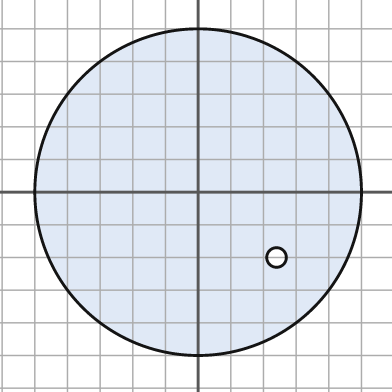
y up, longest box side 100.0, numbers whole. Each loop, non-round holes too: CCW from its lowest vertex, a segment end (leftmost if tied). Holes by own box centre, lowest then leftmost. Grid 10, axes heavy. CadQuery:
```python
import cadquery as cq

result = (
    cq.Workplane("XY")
    .moveTo(0.0, 0.0)
    .circle(50.0)
    .moveTo(24.0, -20.0)
    .circle(3.0)
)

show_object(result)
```